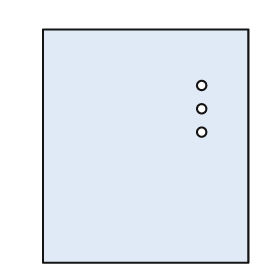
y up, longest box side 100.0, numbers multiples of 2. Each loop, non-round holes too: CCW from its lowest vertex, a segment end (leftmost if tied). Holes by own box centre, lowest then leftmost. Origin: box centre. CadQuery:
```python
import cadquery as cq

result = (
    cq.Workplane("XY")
    .moveTo(-44.0, -50.0)
    .lineTo(44.0, -50.0)
    .lineTo(44.0, 50.0)
    .lineTo(-44.0, 50.0)
    .close()
    .moveTo(24.0, 6.0)
    .circle(2.0)
    .moveTo(24.0, 16.0)
    .circle(2.0)
    .moveTo(24.0, 26.0)
    .circle(2.0)
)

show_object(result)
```